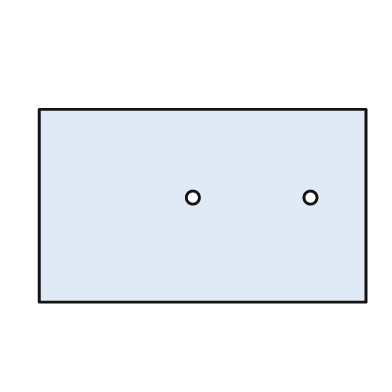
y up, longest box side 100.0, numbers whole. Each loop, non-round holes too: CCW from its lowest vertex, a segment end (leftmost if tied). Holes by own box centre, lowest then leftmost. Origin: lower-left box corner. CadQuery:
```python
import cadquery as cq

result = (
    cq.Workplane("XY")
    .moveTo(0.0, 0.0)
    .lineTo(100.0, 0.0)
    .lineTo(100.0, 59.0)
    .lineTo(0.0, 59.0)
    .close()
    .moveTo(47.0, 32.0)
    .circle(2.0)
    .moveTo(83.0, 32.0)
    .circle(2.0)
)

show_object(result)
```